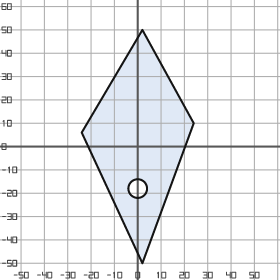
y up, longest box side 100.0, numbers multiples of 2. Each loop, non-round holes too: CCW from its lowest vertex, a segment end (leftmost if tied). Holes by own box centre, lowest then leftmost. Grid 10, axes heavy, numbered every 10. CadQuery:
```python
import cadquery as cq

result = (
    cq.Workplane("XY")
    .moveTo(2.0, -50.0)
    .lineTo(24.0, 10.0)
    .lineTo(2.0, 50.0)
    .lineTo(-24.0, 6.0)
    .close()
    .moveTo(0.0, -18.0)
    .circle(4.0)
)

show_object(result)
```